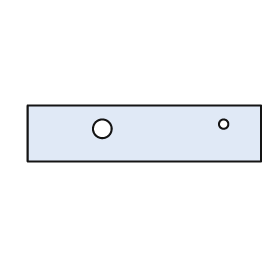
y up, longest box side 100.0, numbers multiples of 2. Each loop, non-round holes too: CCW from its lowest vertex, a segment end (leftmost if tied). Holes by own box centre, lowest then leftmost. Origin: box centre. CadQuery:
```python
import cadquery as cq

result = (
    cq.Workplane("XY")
    .moveTo(-50.0, -12.0)
    .lineTo(50.0, -12.0)
    .lineTo(50.0, 12.0)
    .lineTo(-50.0, 12.0)
    .close()
    .moveTo(-18.0, 2.0)
    .circle(4.0)
    .moveTo(34.0, 4.0)
    .circle(2.0)
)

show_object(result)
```